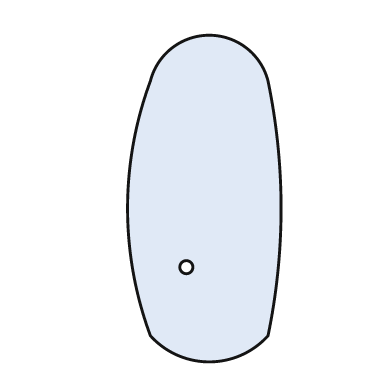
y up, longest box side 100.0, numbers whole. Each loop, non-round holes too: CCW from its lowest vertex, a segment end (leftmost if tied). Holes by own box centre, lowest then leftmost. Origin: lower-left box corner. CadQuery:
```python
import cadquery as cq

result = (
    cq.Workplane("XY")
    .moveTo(7.0, 8.0)
    .threePointArc((25.0, 0.0), (43.0, 8.0))
    .threePointArc((47.0, 47.0), (43.0, 86.0))
    .threePointArc((25.0, 100.0), (7.0, 86.0))
    .threePointArc((0.0, 47.0), (7.0, 8.0))
    .close()
    .moveTo(18.0, 29.0)
    .circle(2.0)
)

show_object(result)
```